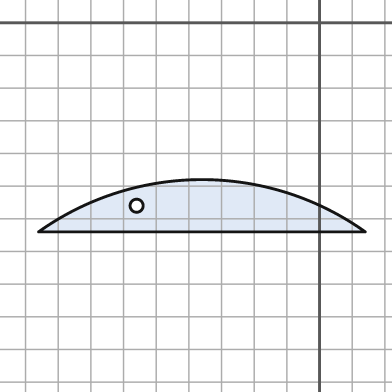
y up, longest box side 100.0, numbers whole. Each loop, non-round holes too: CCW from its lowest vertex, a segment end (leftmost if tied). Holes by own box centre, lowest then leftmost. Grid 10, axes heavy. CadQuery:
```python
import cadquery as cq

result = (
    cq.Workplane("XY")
    .moveTo(-86.0, -64.0)
    .lineTo(14.0, -64.0)
    .threePointArc((-36.0, -48.0), (-86.0, -64.0))
    .close()
    .moveTo(-56.0, -56.0)
    .circle(2.0)
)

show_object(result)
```